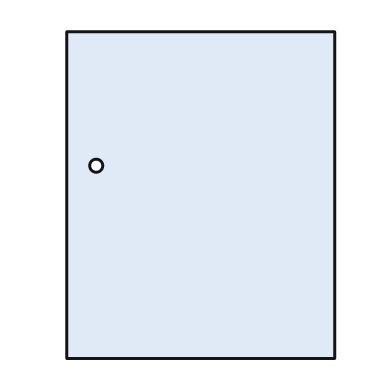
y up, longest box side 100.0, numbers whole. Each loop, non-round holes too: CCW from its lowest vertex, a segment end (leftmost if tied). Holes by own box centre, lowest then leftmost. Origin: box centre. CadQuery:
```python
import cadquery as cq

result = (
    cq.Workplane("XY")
    .moveTo(-41.0, -50.0)
    .lineTo(41.0, -50.0)
    .lineTo(41.0, 50.0)
    .lineTo(-41.0, 50.0)
    .close()
    .moveTo(-32.0, 9.0)
    .circle(2.0)
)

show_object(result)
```